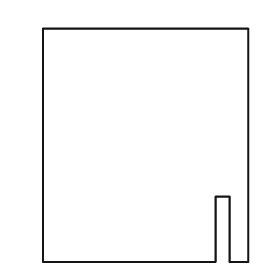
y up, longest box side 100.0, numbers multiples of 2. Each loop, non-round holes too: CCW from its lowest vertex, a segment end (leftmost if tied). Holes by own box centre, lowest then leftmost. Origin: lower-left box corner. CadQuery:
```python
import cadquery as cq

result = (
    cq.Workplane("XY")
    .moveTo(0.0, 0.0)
    .lineTo(74.0, 0.0)
    .lineTo(74.0, 28.0)
    .lineTo(80.0, 28.0)
    .lineTo(80.0, 0.0)
    .lineTo(88.0, 0.0)
    .lineTo(88.0, 100.0)
    .lineTo(0.0, 100.0)
    .close()
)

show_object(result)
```